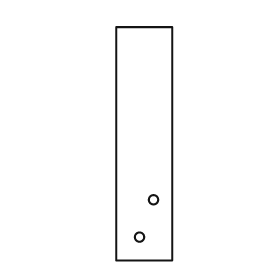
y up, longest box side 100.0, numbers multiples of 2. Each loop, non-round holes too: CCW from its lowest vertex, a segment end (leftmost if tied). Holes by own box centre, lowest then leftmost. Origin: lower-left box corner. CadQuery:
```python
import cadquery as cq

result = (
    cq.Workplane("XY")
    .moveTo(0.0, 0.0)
    .lineTo(24.0, 0.0)
    .lineTo(24.0, 100.0)
    .lineTo(0.0, 100.0)
    .close()
    .moveTo(10.0, 10.0)
    .circle(2.0)
    .moveTo(16.0, 26.0)
    .circle(2.0)
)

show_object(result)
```